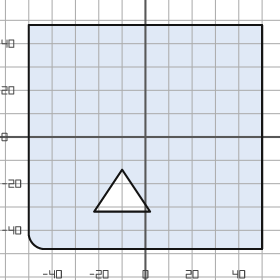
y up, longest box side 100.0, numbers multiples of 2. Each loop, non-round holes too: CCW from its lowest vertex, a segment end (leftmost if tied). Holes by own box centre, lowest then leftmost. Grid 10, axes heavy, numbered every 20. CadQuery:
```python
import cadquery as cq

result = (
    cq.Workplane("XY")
    .moveTo(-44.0, -48.0)
    .lineTo(50.0, -48.0)
    .lineTo(50.0, 48.0)
    .lineTo(-50.0, 48.0)
    .lineTo(-50.0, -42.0)
    .threePointArc((-48.0, -46.0), (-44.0, -48.0))
    .close()
    .moveTo(-22.0, -32.0)
    .lineTo(2.0, -32.0)
    .lineTo(-10.0, -14.0)
    .close()
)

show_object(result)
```